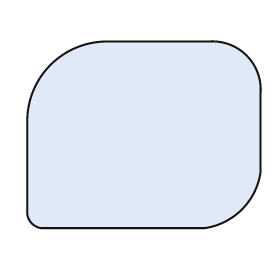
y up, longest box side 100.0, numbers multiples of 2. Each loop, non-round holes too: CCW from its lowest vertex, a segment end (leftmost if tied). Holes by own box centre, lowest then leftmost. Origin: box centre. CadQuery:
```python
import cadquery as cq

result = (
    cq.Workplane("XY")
    .moveTo(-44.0, -40.0)
    .lineTo(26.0, -40.0)
    .threePointArc((42.0, -32.0), (50.0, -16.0))
    .lineTo(50.0, 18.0)
    .threePointArc((44.0, 34.0), (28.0, 40.0))
    .lineTo(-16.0, 40.0)
    .threePointArc((-40.0, 30.0), (-50.0, 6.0))
    .lineTo(-50.0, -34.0)
    .threePointArc((-48.0, -38.0), (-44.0, -40.0))
    .close()
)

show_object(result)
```